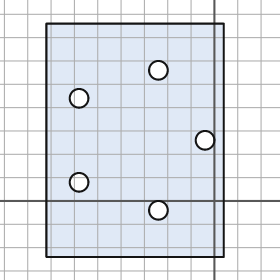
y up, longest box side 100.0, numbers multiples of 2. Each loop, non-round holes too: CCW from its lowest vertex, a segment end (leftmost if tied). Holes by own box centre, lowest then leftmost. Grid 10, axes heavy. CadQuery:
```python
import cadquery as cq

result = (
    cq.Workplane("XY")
    .moveTo(-72.0, -24.0)
    .lineTo(4.0, -24.0)
    .lineTo(4.0, 76.0)
    .lineTo(-72.0, 76.0)
    .close()
    .moveTo(-24.0, -4.0)
    .circle(4.0)
    .moveTo(-58.0, 8.0)
    .circle(4.0)
    .moveTo(-4.0, 26.0)
    .circle(4.0)
    .moveTo(-58.0, 44.0)
    .circle(4.0)
    .moveTo(-24.0, 56.0)
    .circle(4.0)
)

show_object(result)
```